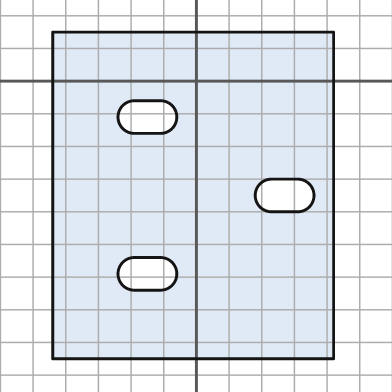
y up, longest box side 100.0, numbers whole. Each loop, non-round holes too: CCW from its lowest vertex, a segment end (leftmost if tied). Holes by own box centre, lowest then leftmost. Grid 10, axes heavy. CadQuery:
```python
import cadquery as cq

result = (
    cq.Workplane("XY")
    .moveTo(-44.0, -85.0)
    .lineTo(42.0, -85.0)
    .lineTo(42.0, 15.0)
    .lineTo(-44.0, 15.0)
    .close()
    .moveTo(-19.0, -64.0)
    .lineTo(-11.0, -64.0)
    .threePointArc((-6.0, -59.0), (-11.0, -54.0))
    .lineTo(-19.0, -54.0)
    .threePointArc((-24.0, -59.0), (-19.0, -64.0))
    .close()
    .moveTo(23.0, -40.0)
    .lineTo(31.0, -40.0)
    .threePointArc((36.0, -35.0), (31.0, -30.0))
    .lineTo(23.0, -30.0)
    .threePointArc((18.0, -35.0), (23.0, -40.0))
    .close()
    .moveTo(-19.0, -16.0)
    .lineTo(-11.0, -16.0)
    .threePointArc((-6.0, -11.0), (-11.0, -6.0))
    .lineTo(-19.0, -6.0)
    .threePointArc((-24.0, -11.0), (-19.0, -16.0))
    .close()
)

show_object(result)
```